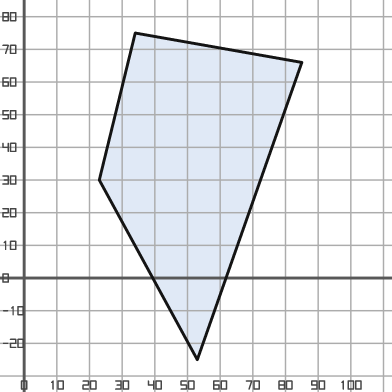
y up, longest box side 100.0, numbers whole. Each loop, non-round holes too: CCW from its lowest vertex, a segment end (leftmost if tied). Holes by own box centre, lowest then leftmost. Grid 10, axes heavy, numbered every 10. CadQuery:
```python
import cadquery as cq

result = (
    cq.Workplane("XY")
    .moveTo(53.0, -25.0)
    .lineTo(85.0, 66.0)
    .lineTo(34.0, 75.0)
    .lineTo(23.0, 30.0)
    .close()
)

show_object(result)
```